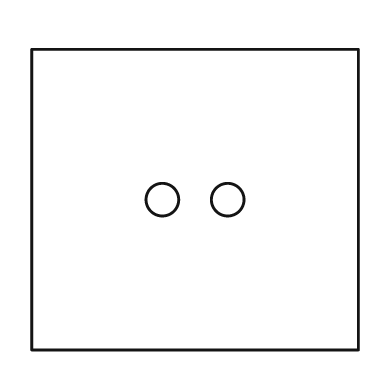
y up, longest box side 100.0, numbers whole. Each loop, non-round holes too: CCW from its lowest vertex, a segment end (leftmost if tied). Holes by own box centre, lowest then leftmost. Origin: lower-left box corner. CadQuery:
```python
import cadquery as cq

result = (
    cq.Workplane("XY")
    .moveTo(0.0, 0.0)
    .lineTo(100.0, 0.0)
    .lineTo(100.0, 92.0)
    .lineTo(0.0, 92.0)
    .close()
    .moveTo(40.0, 46.0)
    .circle(5.0)
    .moveTo(60.0, 46.0)
    .circle(5.0)
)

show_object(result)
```